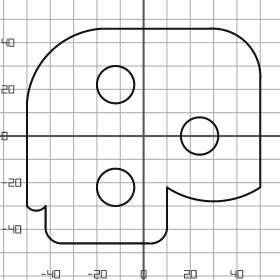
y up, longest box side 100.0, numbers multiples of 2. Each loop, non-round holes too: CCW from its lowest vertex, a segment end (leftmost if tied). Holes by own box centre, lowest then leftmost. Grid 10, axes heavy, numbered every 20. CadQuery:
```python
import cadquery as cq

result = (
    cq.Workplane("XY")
    .moveTo(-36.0, -46.0)
    .lineTo(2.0, -46.0)
    .threePointArc((8.0, -44.0), (10.0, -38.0))
    .lineTo(10.0, -22.0)
    .threePointArc((30.0, -28.0), (50.0, -22.0))
    .lineTo(50.0, 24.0)
    .threePointArc((44.0, 40.0), (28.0, 46.0))
    .lineTo(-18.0, 46.0)
    .threePointArc((-40.0, 36.0), (-50.0, 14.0))
    .lineTo(-50.0, -30.0)
    .threePointArc((-46.0, -32.0), (-42.0, -30.0))
    .lineTo(-42.0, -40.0)
    .threePointArc((-40.0, -44.0), (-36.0, -46.0))
    .close()
    .moveTo(-12.0, -22.0)
    .circle(8.0)
    .moveTo(24.0, 0.0)
    .circle(8.0)
    .moveTo(-12.0, 22.0)
    .circle(8.0)
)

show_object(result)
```